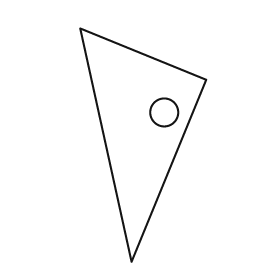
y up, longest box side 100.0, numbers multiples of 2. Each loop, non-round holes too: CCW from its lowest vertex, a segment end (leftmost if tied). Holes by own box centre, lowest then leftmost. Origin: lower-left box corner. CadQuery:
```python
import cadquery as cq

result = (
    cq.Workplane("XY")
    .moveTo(22.0, 0.0)
    .lineTo(54.0, 78.0)
    .lineTo(0.0, 100.0)
    .close()
    .moveTo(36.0, 64.0)
    .circle(6.0)
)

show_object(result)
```